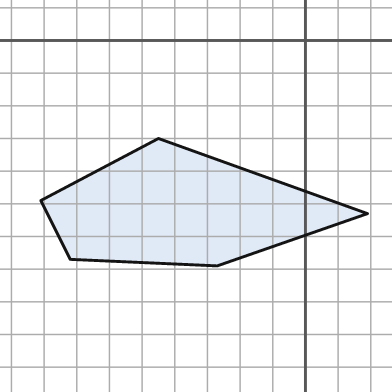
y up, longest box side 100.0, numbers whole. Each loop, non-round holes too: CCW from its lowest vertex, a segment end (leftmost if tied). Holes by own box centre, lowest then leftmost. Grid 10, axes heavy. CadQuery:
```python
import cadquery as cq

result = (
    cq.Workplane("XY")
    .moveTo(-27.0, -69.0)
    .lineTo(19.0, -53.0)
    .lineTo(-45.0, -30.0)
    .lineTo(-81.0, -49.0)
    .lineTo(-72.0, -67.0)
    .close()
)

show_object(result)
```